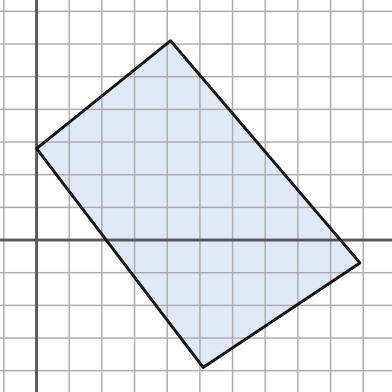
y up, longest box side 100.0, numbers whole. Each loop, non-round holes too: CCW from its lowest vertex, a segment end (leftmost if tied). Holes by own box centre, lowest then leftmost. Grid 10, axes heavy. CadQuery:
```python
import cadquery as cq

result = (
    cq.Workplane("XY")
    .moveTo(51.0, -39.0)
    .lineTo(99.0, -7.0)
    .lineTo(41.0, 61.0)
    .lineTo(0.0, 28.0)
    .close()
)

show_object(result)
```